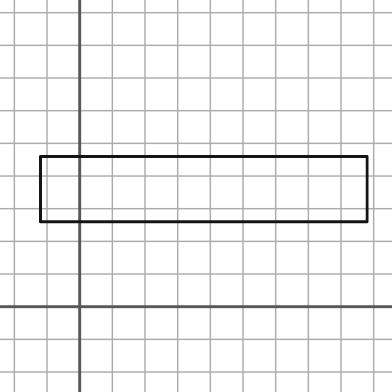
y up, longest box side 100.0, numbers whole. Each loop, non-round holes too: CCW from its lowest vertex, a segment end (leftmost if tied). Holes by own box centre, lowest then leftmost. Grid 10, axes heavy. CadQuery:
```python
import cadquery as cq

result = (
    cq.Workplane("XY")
    .moveTo(-12.0, 26.0)
    .lineTo(88.0, 26.0)
    .lineTo(88.0, 46.0)
    .lineTo(-12.0, 46.0)
    .close()
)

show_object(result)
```